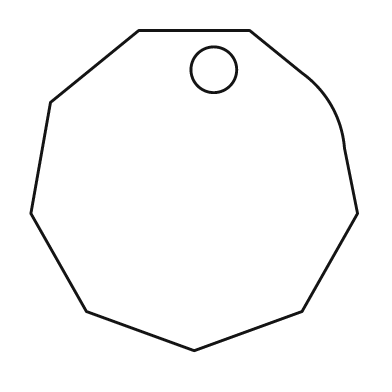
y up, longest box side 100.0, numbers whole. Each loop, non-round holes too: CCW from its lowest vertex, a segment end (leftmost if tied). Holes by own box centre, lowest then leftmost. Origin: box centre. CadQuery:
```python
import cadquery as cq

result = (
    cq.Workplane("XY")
    .moveTo(0.0, -49.0)
    .lineTo(33.0, -37.0)
    .lineTo(50.0, -7.0)
    .lineTo(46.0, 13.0)
    .threePointArc((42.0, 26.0), (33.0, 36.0))
    .lineTo(17.0, 49.0)
    .lineTo(-17.0, 49.0)
    .lineTo(-44.0, 27.0)
    .lineTo(-50.0, -7.0)
    .lineTo(-33.0, -37.0)
    .close()
    .moveTo(6.0, 37.0)
    .circle(7.0)
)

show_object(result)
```